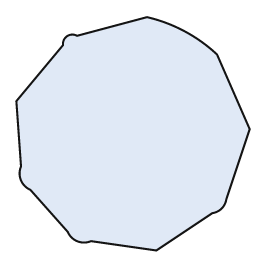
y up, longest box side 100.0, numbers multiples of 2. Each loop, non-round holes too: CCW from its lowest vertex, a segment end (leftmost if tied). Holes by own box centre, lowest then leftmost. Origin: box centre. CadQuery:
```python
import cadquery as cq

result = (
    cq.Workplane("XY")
    .moveTo(10.0, -50.0)
    .lineTo(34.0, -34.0)
    .threePointArc((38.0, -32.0), (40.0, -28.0))
    .lineTo(50.0, 2.0)
    .lineTo(36.0, 34.0)
    .threePointArc((22.0, 44.0), (6.0, 50.0))
    .lineTo(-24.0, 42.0)
    .threePointArc((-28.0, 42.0), (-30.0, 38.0))
    .lineTo(-50.0, 14.0)
    .lineTo(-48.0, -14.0)
    .threePointArc((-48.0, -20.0), (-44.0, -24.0))
    .lineTo(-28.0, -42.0)
    .threePointArc((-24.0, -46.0), (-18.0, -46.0))
    .close()
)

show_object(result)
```